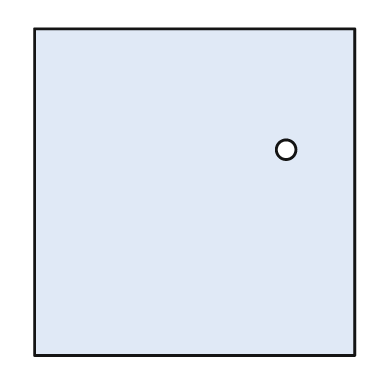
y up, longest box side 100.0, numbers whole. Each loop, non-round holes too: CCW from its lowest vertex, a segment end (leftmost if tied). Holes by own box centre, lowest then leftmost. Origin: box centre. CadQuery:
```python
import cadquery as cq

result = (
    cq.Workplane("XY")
    .moveTo(-49.0, -50.0)
    .lineTo(49.0, -50.0)
    .lineTo(49.0, 50.0)
    .lineTo(-49.0, 50.0)
    .close()
    .moveTo(28.0, 13.0)
    .circle(3.0)
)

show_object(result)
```